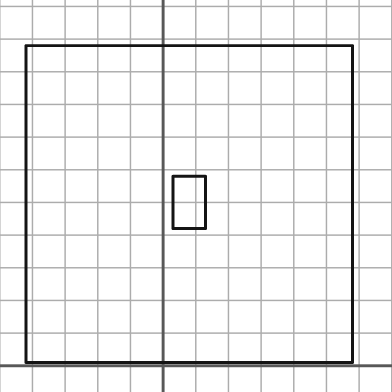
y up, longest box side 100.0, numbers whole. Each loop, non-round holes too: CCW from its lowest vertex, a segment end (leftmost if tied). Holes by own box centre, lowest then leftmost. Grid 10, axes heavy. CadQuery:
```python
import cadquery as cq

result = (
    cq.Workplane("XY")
    .moveTo(-42.0, 1.0)
    .lineTo(58.0, 1.0)
    .lineTo(58.0, 98.0)
    .lineTo(-42.0, 98.0)
    .close()
    .moveTo(3.0, 42.0)
    .lineTo(13.0, 42.0)
    .lineTo(13.0, 58.0)
    .lineTo(3.0, 58.0)
    .close()
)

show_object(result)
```